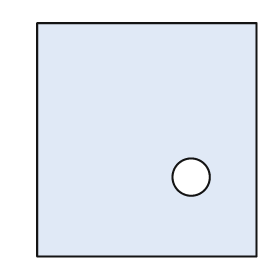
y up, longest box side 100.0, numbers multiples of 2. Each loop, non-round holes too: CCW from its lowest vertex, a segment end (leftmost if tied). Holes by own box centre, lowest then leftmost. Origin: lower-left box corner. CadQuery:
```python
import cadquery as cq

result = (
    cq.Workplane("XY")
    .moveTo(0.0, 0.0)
    .lineTo(94.0, 0.0)
    .lineTo(94.0, 100.0)
    .lineTo(0.0, 100.0)
    .close()
    .moveTo(66.0, 34.0)
    .circle(8.0)
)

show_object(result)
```